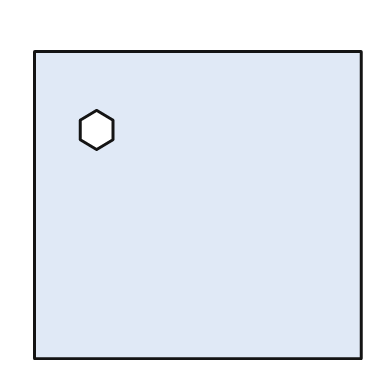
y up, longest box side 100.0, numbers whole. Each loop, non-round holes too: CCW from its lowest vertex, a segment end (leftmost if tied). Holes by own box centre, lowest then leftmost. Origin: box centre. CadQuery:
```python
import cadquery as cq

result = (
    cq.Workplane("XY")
    .moveTo(-50.0, -47.0)
    .lineTo(50.0, -47.0)
    .lineTo(50.0, 47.0)
    .lineTo(-50.0, 47.0)
    .close()
    .moveTo(-31.0, 17.0)
    .lineTo(-26.0, 20.0)
    .lineTo(-26.0, 26.0)
    .lineTo(-31.0, 29.0)
    .lineTo(-36.0, 26.0)
    .lineTo(-36.0, 20.0)
    .close()
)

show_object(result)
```